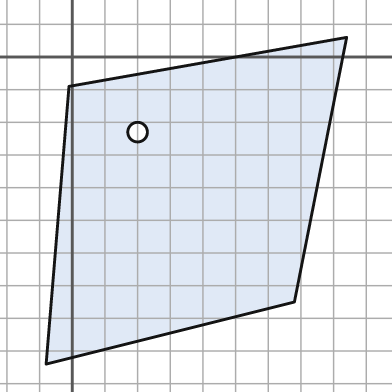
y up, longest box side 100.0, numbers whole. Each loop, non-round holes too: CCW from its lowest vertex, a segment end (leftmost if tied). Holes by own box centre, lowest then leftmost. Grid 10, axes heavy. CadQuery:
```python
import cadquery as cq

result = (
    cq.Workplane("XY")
    .moveTo(-8.0, -94.0)
    .lineTo(68.0, -75.0)
    .lineTo(84.0, 6.0)
    .lineTo(-1.0, -9.0)
    .close()
    .moveTo(20.0, -23.0)
    .circle(3.0)
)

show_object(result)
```